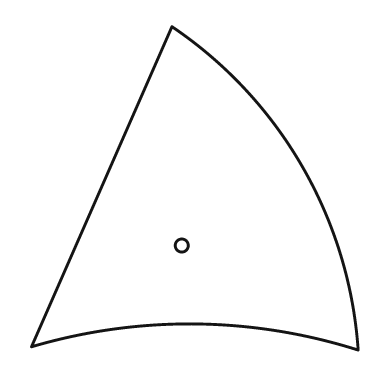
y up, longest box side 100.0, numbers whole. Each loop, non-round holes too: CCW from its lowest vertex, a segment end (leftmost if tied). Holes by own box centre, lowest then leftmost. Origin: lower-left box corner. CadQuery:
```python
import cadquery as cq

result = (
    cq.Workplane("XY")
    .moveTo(100.0, 0.0)
    .threePointArc((83.0, 56.0), (43.0, 99.0))
    .lineTo(0.0, 1.0)
    .threePointArc((50.0, 8.0), (100.0, 0.0))
    .close()
    .moveTo(46.0, 32.0)
    .circle(2.0)
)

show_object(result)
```